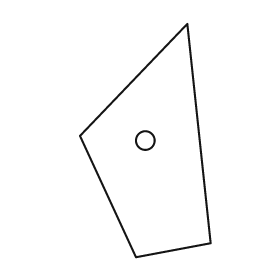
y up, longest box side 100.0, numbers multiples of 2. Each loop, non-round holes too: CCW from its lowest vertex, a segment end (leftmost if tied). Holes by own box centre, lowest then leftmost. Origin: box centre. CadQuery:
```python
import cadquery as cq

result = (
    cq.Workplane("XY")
    .moveTo(-4.0, -50.0)
    .lineTo(28.0, -44.0)
    .lineTo(18.0, 50.0)
    .lineTo(-28.0, 2.0)
    .close()
    .moveTo(0.0, 0.0)
    .circle(4.0)
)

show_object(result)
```